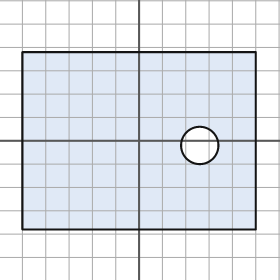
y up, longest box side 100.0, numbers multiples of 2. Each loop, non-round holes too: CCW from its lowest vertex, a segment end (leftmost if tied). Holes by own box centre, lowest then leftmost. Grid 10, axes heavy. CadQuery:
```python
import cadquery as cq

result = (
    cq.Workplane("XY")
    .moveTo(-50.0, -38.0)
    .lineTo(50.0, -38.0)
    .lineTo(50.0, 38.0)
    .lineTo(-50.0, 38.0)
    .close()
    .moveTo(26.0, -2.0)
    .circle(8.0)
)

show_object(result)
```